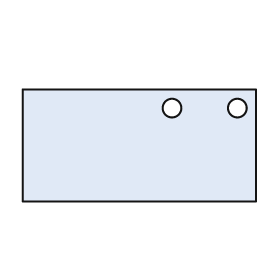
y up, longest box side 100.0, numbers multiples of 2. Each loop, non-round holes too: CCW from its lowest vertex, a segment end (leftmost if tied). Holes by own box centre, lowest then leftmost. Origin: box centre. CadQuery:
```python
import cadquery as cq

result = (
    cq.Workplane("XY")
    .moveTo(-50.0, -24.0)
    .lineTo(50.0, -24.0)
    .lineTo(50.0, 24.0)
    .lineTo(-50.0, 24.0)
    .close()
    .moveTo(14.0, 16.0)
    .circle(4.0)
    .moveTo(42.0, 16.0)
    .circle(4.0)
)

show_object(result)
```